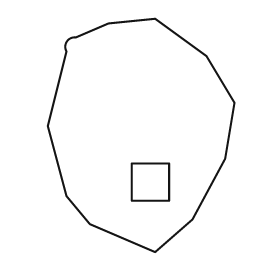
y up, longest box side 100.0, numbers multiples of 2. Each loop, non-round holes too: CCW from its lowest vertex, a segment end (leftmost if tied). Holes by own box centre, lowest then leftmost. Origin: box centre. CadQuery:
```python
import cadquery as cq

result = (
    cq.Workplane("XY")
    .moveTo(6.0, -50.0)
    .lineTo(22.0, -36.0)
    .lineTo(36.0, -10.0)
    .lineTo(40.0, 14.0)
    .lineTo(28.0, 34.0)
    .lineTo(6.0, 50.0)
    .lineTo(-14.0, 48.0)
    .lineTo(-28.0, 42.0)
    .threePointArc((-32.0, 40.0), (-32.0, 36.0))
    .lineTo(-40.0, 4.0)
    .lineTo(-32.0, -26.0)
    .lineTo(-22.0, -38.0)
    .close()
    .moveTo(-4.0, -28.0)
    .lineTo(12.0, -28.0)
    .lineTo(12.0, -12.0)
    .lineTo(-4.0, -12.0)
    .close()
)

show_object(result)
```